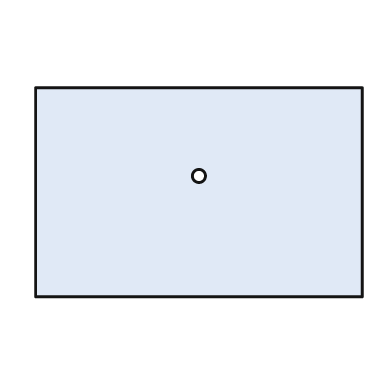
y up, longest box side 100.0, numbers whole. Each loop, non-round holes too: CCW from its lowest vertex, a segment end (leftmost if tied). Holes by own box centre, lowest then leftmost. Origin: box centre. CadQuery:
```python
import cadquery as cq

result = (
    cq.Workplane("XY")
    .moveTo(-50.0, -32.0)
    .lineTo(50.0, -32.0)
    .lineTo(50.0, 32.0)
    .lineTo(-50.0, 32.0)
    .close()
    .moveTo(0.0, 5.0)
    .circle(2.0)
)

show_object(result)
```